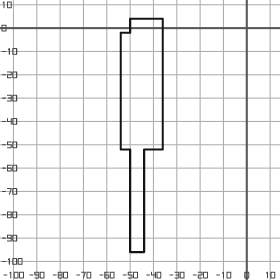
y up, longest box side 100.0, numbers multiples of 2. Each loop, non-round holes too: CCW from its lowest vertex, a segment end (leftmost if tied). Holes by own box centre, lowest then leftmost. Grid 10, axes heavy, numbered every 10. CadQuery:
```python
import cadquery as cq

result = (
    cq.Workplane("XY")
    .moveTo(-50.0, -96.0)
    .lineTo(-44.0, -96.0)
    .lineTo(-44.0, -52.0)
    .lineTo(-36.0, -52.0)
    .lineTo(-36.0, 4.0)
    .lineTo(-50.0, 4.0)
    .lineTo(-50.0, -2.0)
    .lineTo(-54.0, -2.0)
    .lineTo(-54.0, -52.0)
    .lineTo(-50.0, -52.0)
    .close()
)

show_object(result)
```